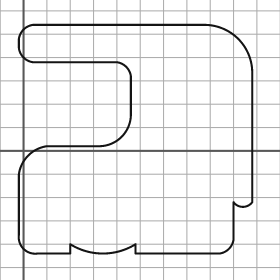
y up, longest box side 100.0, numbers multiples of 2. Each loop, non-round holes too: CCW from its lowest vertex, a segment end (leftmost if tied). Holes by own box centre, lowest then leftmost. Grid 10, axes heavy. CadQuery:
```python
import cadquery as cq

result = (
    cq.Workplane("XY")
    .moveTo(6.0, -44.0)
    .lineTo(20.0, -44.0)
    .lineTo(20.0, -40.0)
    .threePointArc((34.0, -44.0), (48.0, -40.0))
    .lineTo(48.0, -44.0)
    .lineTo(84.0, -44.0)
    .threePointArc((88.0, -42.0), (90.0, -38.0))
    .lineTo(90.0, -22.0)
    .threePointArc((94.0, -24.0), (98.0, -22.0))
    .lineTo(98.0, 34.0)
    .threePointArc((92.0, 48.0), (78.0, 54.0))
    .lineTo(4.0, 54.0)
    .threePointArc((0.0, 52.0), (-2.0, 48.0))
    .lineTo(-2.0, 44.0)
    .threePointArc((0.0, 40.0), (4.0, 38.0))
    .lineTo(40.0, 38.0)
    .threePointArc((44.0, 36.0), (46.0, 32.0))
    .lineTo(46.0, 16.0)
    .threePointArc((42.0, 6.0), (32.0, 2.0))
    .lineTo(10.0, 2.0)
    .threePointArc((2.0, -2.0), (-2.0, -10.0))
    .lineTo(-2.0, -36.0)
    .threePointArc((0.0, -42.0), (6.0, -44.0))
    .close()
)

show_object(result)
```